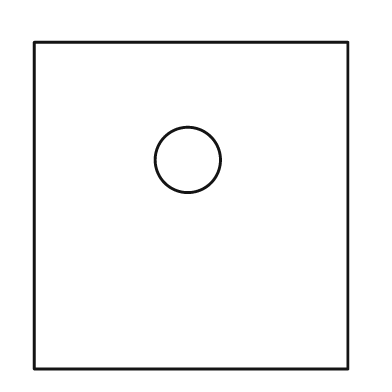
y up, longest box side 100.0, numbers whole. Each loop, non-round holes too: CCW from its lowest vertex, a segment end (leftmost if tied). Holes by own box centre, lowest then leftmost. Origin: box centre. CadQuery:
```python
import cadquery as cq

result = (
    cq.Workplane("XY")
    .moveTo(-48.0, -50.0)
    .lineTo(48.0, -50.0)
    .lineTo(48.0, 50.0)
    .lineTo(-48.0, 50.0)
    .close()
    .moveTo(-1.0, 14.0)
    .circle(10.0)
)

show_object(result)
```